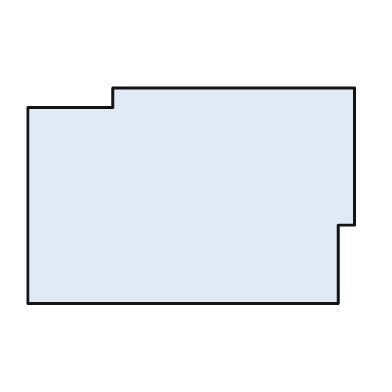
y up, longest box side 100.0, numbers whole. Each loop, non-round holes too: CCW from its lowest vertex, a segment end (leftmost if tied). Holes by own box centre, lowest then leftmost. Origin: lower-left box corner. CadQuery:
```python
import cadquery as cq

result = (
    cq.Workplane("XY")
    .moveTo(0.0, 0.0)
    .lineTo(95.0, 0.0)
    .lineTo(95.0, 24.0)
    .lineTo(100.0, 24.0)
    .lineTo(100.0, 66.0)
    .lineTo(26.0, 66.0)
    .lineTo(26.0, 60.0)
    .lineTo(0.0, 60.0)
    .close()
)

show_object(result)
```